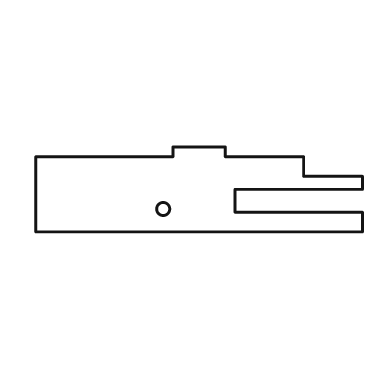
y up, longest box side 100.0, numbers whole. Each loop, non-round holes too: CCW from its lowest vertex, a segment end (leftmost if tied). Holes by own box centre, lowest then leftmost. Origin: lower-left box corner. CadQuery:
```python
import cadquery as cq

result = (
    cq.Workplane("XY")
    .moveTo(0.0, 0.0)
    .lineTo(100.0, 0.0)
    .lineTo(100.0, 6.0)
    .lineTo(61.0, 6.0)
    .lineTo(61.0, 13.0)
    .lineTo(100.0, 13.0)
    .lineTo(100.0, 17.0)
    .lineTo(82.0, 17.0)
    .lineTo(82.0, 23.0)
    .lineTo(58.0, 23.0)
    .lineTo(58.0, 26.0)
    .lineTo(42.0, 26.0)
    .lineTo(42.0, 23.0)
    .lineTo(0.0, 23.0)
    .close()
    .moveTo(39.0, 7.0)
    .circle(2.0)
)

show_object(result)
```